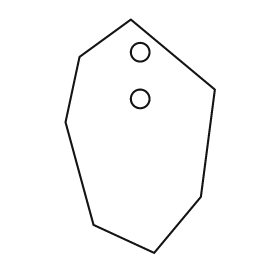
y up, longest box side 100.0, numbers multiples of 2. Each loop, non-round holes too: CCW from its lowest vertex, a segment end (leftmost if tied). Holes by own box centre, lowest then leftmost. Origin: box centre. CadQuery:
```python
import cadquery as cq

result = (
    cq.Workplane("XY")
    .moveTo(6.0, -50.0)
    .lineTo(26.0, -26.0)
    .lineTo(32.0, 20.0)
    .lineTo(-4.0, 50.0)
    .lineTo(-26.0, 34.0)
    .lineTo(-32.0, 6.0)
    .lineTo(-20.0, -38.0)
    .close()
    .moveTo(0.0, 16.0)
    .circle(4.0)
    .moveTo(0.0, 36.0)
    .circle(4.0)
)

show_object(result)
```